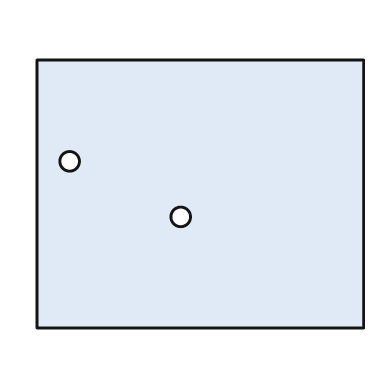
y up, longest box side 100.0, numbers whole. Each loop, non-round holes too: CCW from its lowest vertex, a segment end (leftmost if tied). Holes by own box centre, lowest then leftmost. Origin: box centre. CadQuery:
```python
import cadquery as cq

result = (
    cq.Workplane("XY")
    .moveTo(-50.0, -41.0)
    .lineTo(50.0, -41.0)
    .lineTo(50.0, 41.0)
    .lineTo(-50.0, 41.0)
    .close()
    .moveTo(-6.0, -7.0)
    .circle(3.0)
    .moveTo(-40.0, 10.0)
    .circle(3.0)
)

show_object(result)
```